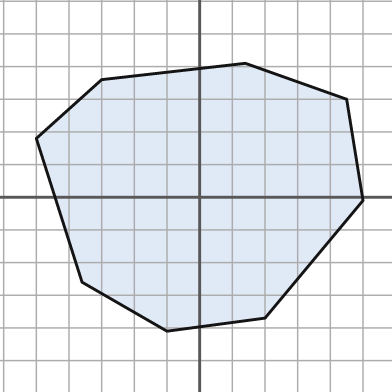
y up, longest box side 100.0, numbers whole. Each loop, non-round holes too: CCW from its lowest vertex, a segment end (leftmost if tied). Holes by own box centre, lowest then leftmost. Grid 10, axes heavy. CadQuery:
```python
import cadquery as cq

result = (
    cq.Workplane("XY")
    .moveTo(-10.0, -41.0)
    .lineTo(20.0, -37.0)
    .lineTo(50.0, -1.0)
    .lineTo(45.0, 30.0)
    .lineTo(14.0, 41.0)
    .lineTo(-30.0, 36.0)
    .lineTo(-50.0, 18.0)
    .lineTo(-36.0, -26.0)
    .close()
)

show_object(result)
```